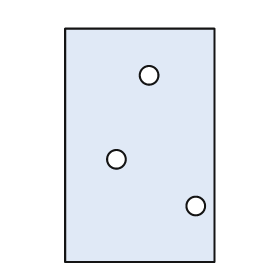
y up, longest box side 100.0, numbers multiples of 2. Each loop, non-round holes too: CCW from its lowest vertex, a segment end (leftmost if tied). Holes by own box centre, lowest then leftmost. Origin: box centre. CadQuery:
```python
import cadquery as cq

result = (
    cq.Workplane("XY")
    .moveTo(-32.0, -50.0)
    .lineTo(32.0, -50.0)
    .lineTo(32.0, 50.0)
    .lineTo(-32.0, 50.0)
    .close()
    .moveTo(24.0, -26.0)
    .circle(4.0)
    .moveTo(-10.0, -6.0)
    .circle(4.0)
    .moveTo(4.0, 30.0)
    .circle(4.0)
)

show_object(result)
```